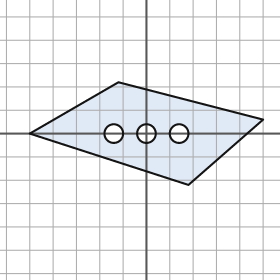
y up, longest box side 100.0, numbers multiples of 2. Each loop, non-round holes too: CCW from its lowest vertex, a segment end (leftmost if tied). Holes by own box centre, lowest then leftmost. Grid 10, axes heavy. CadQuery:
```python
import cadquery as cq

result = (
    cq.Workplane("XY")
    .moveTo(18.0, -22.0)
    .lineTo(50.0, 6.0)
    .lineTo(-12.0, 22.0)
    .lineTo(-50.0, 0.0)
    .close()
    .moveTo(-14.0, 0.0)
    .circle(4.0)
    .moveTo(0.0, 0.0)
    .circle(4.0)
    .moveTo(14.0, 0.0)
    .circle(4.0)
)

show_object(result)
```